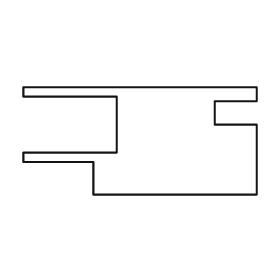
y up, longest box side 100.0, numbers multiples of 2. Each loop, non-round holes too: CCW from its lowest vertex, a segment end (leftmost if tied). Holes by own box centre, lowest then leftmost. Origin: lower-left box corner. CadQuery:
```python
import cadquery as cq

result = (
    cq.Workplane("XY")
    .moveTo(30.0, 0.0)
    .lineTo(100.0, 0.0)
    .lineTo(100.0, 30.0)
    .lineTo(82.0, 30.0)
    .lineTo(82.0, 40.0)
    .lineTo(100.0, 40.0)
    .lineTo(100.0, 46.0)
    .lineTo(0.0, 46.0)
    .lineTo(0.0, 42.0)
    .lineTo(40.0, 42.0)
    .lineTo(40.0, 18.0)
    .lineTo(0.0, 18.0)
    .lineTo(0.0, 14.0)
    .lineTo(30.0, 14.0)
    .close()
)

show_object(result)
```